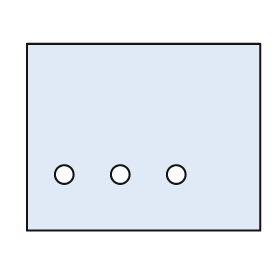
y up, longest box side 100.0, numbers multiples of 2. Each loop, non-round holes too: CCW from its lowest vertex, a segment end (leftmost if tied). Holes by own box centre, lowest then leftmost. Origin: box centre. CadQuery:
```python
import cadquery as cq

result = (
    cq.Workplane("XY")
    .moveTo(-50.0, -40.0)
    .lineTo(50.0, -40.0)
    .lineTo(50.0, 40.0)
    .lineTo(-50.0, 40.0)
    .close()
    .moveTo(-34.0, -16.0)
    .circle(4.0)
    .moveTo(-10.0, -16.0)
    .circle(4.0)
    .moveTo(14.0, -16.0)
    .circle(4.0)
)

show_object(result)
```